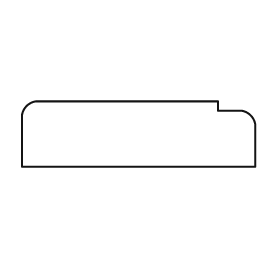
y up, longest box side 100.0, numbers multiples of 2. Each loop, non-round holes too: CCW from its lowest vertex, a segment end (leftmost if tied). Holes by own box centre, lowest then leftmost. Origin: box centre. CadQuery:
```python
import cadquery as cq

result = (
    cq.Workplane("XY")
    .moveTo(-50.0, -14.0)
    .lineTo(50.0, -14.0)
    .lineTo(50.0, 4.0)
    .threePointArc((48.0, 8.0), (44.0, 10.0))
    .lineTo(34.0, 10.0)
    .lineTo(34.0, 14.0)
    .lineTo(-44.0, 14.0)
    .threePointArc((-48.0, 12.0), (-50.0, 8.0))
    .close()
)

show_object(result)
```